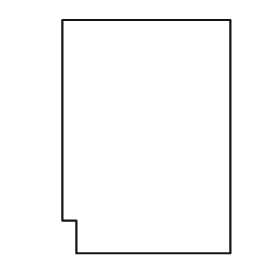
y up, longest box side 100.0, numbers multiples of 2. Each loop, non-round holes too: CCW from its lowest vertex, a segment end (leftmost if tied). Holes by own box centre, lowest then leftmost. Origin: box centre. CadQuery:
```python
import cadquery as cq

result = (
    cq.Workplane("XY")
    .moveTo(-30.0, -50.0)
    .lineTo(36.0, -50.0)
    .lineTo(36.0, 50.0)
    .lineTo(-36.0, 50.0)
    .lineTo(-36.0, -36.0)
    .lineTo(-30.0, -36.0)
    .close()
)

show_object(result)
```